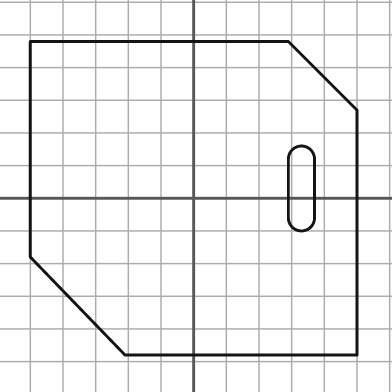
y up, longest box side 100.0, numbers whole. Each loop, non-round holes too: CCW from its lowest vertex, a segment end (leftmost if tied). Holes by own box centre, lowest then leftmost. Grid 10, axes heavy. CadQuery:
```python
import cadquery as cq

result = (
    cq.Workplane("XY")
    .moveTo(-21.0, -48.0)
    .lineTo(50.0, -48.0)
    .lineTo(50.0, 27.0)
    .lineTo(29.0, 48.0)
    .lineTo(-50.0, 48.0)
    .lineTo(-50.0, -18.0)
    .close()
    .moveTo(29.0, -6.0)
    .threePointArc((33.0, -10.0), (37.0, -6.0))
    .lineTo(37.0, 12.0)
    .threePointArc((33.0, 16.0), (29.0, 12.0))
    .close()
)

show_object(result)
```